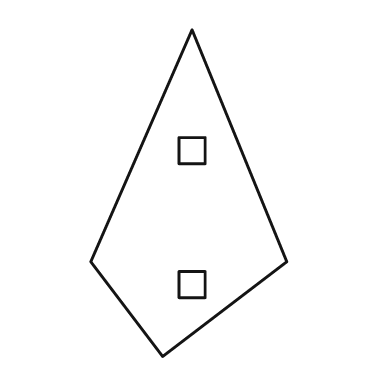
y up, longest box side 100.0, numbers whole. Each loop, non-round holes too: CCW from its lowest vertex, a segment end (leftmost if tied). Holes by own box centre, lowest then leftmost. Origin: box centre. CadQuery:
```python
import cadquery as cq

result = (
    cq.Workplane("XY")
    .moveTo(-8.0, -50.0)
    .lineTo(30.0, -21.0)
    .lineTo(1.0, 50.0)
    .lineTo(-30.0, -21.0)
    .close()
    .moveTo(-3.0, -32.0)
    .lineTo(5.0, -32.0)
    .lineTo(5.0, -24.0)
    .lineTo(-3.0, -24.0)
    .close()
    .moveTo(-3.0, 9.0)
    .lineTo(5.0, 9.0)
    .lineTo(5.0, 17.0)
    .lineTo(-3.0, 17.0)
    .close()
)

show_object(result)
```